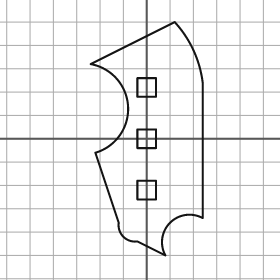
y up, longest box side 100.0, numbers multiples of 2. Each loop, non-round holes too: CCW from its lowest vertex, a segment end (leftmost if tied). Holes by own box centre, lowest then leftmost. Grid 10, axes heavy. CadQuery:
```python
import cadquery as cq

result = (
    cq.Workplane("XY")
    .moveTo(8.0, -50.0)
    .threePointArc((10.0, -36.0), (24.0, -34.0))
    .lineTo(24.0, 24.0)
    .threePointArc((20.0, 38.0), (12.0, 50.0))
    .lineTo(-24.0, 32.0)
    .threePointArc((-8.0, 14.0), (-22.0, -6.0))
    .lineTo(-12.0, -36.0)
    .threePointArc((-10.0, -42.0), (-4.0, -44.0))
    .close()
    .moveTo(-4.0, -26.0)
    .lineTo(4.0, -26.0)
    .lineTo(4.0, -18.0)
    .lineTo(-4.0, -18.0)
    .close()
    .moveTo(-4.0, -4.0)
    .lineTo(4.0, -4.0)
    .lineTo(4.0, 4.0)
    .lineTo(-4.0, 4.0)
    .close()
    .moveTo(-4.0, 18.0)
    .lineTo(4.0, 18.0)
    .lineTo(4.0, 26.0)
    .lineTo(-4.0, 26.0)
    .close()
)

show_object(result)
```